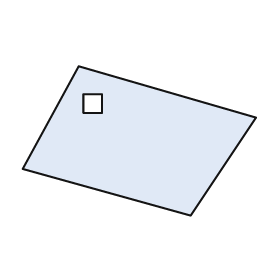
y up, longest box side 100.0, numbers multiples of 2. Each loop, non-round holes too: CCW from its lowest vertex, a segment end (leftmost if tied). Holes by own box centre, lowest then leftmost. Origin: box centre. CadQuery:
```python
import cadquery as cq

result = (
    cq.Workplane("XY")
    .moveTo(22.0, -32.0)
    .lineTo(50.0, 10.0)
    .lineTo(-26.0, 32.0)
    .lineTo(-50.0, -12.0)
    .close()
    .moveTo(-24.0, 12.0)
    .lineTo(-16.0, 12.0)
    .lineTo(-16.0, 20.0)
    .lineTo(-24.0, 20.0)
    .close()
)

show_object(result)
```